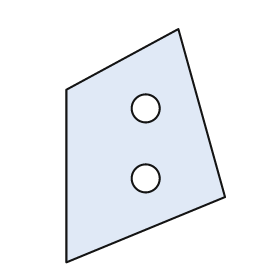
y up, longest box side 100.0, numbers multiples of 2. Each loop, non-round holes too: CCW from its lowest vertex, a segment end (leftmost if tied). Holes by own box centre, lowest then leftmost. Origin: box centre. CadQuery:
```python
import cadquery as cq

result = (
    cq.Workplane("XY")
    .moveTo(-34.0, -50.0)
    .lineTo(34.0, -22.0)
    .lineTo(14.0, 50.0)
    .lineTo(-34.0, 24.0)
    .close()
    .moveTo(0.0, -14.0)
    .circle(6.0)
    .moveTo(0.0, 16.0)
    .circle(6.0)
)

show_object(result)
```